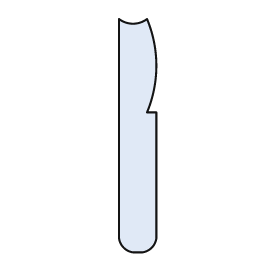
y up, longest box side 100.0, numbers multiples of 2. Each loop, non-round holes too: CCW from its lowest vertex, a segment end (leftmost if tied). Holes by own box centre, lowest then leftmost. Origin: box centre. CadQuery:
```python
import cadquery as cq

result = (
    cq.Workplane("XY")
    .moveTo(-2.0, -50.0)
    .lineTo(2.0, -50.0)
    .threePointArc((6.0, -48.0), (8.0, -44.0))
    .lineTo(8.0, 10.0)
    .lineTo(4.0, 10.0)
    .threePointArc((8.0, 30.0), (4.0, 50.0))
    .threePointArc((-2.0, 48.0), (-8.0, 50.0))
    .lineTo(-8.0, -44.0)
    .threePointArc((-6.0, -48.0), (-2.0, -50.0))
    .close()
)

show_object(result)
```